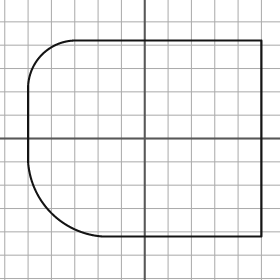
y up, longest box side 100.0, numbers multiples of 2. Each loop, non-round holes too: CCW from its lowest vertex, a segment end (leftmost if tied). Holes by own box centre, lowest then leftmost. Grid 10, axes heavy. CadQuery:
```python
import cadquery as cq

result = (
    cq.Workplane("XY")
    .moveTo(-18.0, -42.0)
    .lineTo(50.0, -42.0)
    .lineTo(50.0, 42.0)
    .lineTo(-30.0, 42.0)
    .threePointArc((-44.0, 36.0), (-50.0, 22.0))
    .lineTo(-50.0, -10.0)
    .threePointArc((-40.0, -32.0), (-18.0, -42.0))
    .close()
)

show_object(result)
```